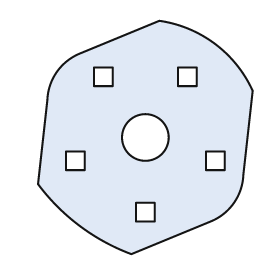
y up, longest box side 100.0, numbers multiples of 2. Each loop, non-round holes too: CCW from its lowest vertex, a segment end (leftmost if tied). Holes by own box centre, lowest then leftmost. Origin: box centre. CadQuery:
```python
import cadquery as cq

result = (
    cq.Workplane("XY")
    .moveTo(-6.0, -50.0)
    .lineTo(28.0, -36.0)
    .threePointArc((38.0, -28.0), (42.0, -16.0))
    .lineTo(46.0, 20.0)
    .threePointArc((30.0, 40.0), (6.0, 50.0))
    .lineTo(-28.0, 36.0)
    .threePointArc((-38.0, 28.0), (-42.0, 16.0))
    .lineTo(-46.0, -20.0)
    .threePointArc((-28.0, -38.0), (-6.0, -50.0))
    .close()
    .moveTo(-4.0, -36.0)
    .lineTo(4.0, -36.0)
    .lineTo(4.0, -28.0)
    .lineTo(-4.0, -28.0)
    .close()
    .moveTo(-34.0, -14.0)
    .lineTo(-26.0, -14.0)
    .lineTo(-26.0, -6.0)
    .lineTo(-34.0, -6.0)
    .close()
    .moveTo(26.0, -14.0)
    .lineTo(34.0, -14.0)
    .lineTo(34.0, -6.0)
    .lineTo(26.0, -6.0)
    .close()
    .moveTo(0.0, 0.0)
    .circle(10.0)
    .moveTo(-22.0, 22.0)
    .lineTo(-14.0, 22.0)
    .lineTo(-14.0, 30.0)
    .lineTo(-22.0, 30.0)
    .close()
    .moveTo(14.0, 22.0)
    .lineTo(22.0, 22.0)
    .lineTo(22.0, 30.0)
    .lineTo(14.0, 30.0)
    .close()
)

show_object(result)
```